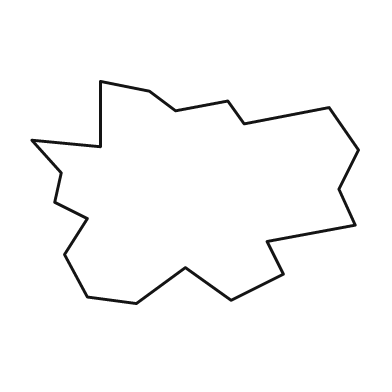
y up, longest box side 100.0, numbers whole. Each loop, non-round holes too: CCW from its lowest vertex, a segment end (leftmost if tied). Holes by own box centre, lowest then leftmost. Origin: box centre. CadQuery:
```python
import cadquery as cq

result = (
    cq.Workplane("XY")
    .moveTo(-18.0, -34.0)
    .lineTo(-3.0, -23.0)
    .lineTo(11.0, -33.0)
    .lineTo(27.0, -25.0)
    .lineTo(22.0, -15.0)
    .lineTo(49.0, -10.0)
    .lineTo(44.0, 1.0)
    .lineTo(50.0, 13.0)
    .lineTo(41.0, 26.0)
    .lineTo(15.0, 21.0)
    .lineTo(10.0, 28.0)
    .lineTo(-6.0, 25.0)
    .lineTo(-14.0, 31.0)
    .lineTo(-29.0, 34.0)
    .lineTo(-29.0, 14.0)
    .lineTo(-50.0, 16.0)
    .lineTo(-41.0, 6.0)
    .lineTo(-43.0, -3.0)
    .lineTo(-33.0, -8.0)
    .lineTo(-40.0, -19.0)
    .lineTo(-33.0, -32.0)
    .close()
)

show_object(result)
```